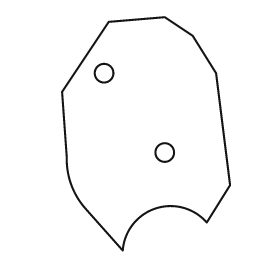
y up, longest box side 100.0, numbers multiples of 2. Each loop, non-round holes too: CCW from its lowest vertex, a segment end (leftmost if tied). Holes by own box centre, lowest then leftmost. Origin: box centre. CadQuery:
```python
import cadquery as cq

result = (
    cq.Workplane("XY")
    .moveTo(-10.0, -50.0)
    .threePointArc((4.0, -32.0), (26.0, -38.0))
    .lineTo(36.0, -22.0)
    .lineTo(30.0, 26.0)
    .lineTo(20.0, 42.0)
    .lineTo(8.0, 50.0)
    .lineTo(-16.0, 48.0)
    .lineTo(-36.0, 18.0)
    .lineTo(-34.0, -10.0)
    .threePointArc((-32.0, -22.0), (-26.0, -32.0))
    .close()
    .moveTo(8.0, -8.0)
    .circle(4.0)
    .moveTo(-18.0, 26.0)
    .circle(4.0)
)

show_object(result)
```